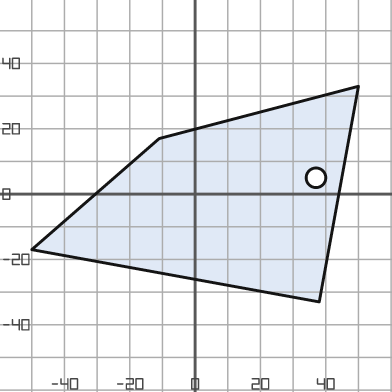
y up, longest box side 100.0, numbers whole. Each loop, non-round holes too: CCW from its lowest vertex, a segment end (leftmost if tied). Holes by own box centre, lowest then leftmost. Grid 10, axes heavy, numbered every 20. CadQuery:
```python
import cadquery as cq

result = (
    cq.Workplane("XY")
    .moveTo(38.0, -33.0)
    .lineTo(50.0, 33.0)
    .lineTo(-11.0, 17.0)
    .lineTo(-50.0, -17.0)
    .close()
    .moveTo(37.0, 5.0)
    .circle(3.0)
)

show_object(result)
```